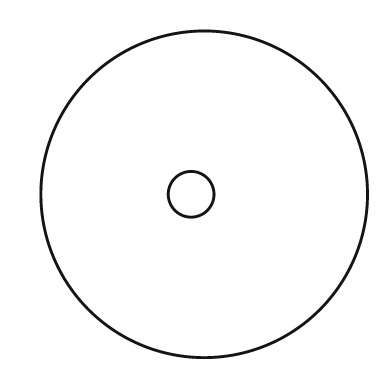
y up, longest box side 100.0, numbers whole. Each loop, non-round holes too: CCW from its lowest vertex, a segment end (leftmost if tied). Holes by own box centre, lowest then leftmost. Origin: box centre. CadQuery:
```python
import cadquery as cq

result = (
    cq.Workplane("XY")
    .moveTo(0.0, 0.0)
    .circle(50.0)
    .moveTo(-4.0, 0.0)
    .circle(7.0)
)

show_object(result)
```